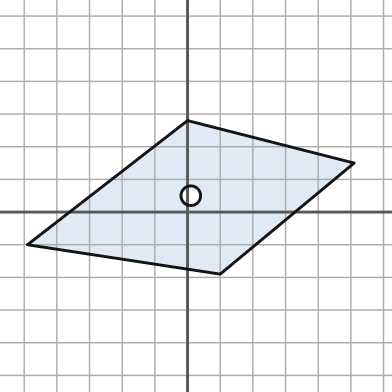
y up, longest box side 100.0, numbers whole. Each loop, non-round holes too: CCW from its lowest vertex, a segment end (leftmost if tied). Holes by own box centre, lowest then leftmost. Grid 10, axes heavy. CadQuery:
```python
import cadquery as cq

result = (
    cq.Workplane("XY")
    .moveTo(10.0, -19.0)
    .lineTo(51.0, 15.0)
    .lineTo(0.0, 28.0)
    .lineTo(-49.0, -10.0)
    .close()
    .moveTo(1.0, 5.0)
    .circle(3.0)
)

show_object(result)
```